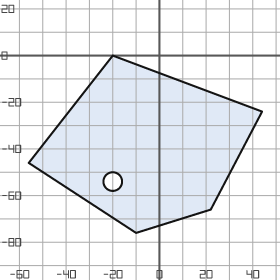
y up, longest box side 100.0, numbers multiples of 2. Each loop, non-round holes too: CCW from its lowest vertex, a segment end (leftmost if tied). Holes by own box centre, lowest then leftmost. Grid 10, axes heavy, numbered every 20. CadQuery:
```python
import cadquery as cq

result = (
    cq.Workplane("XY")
    .moveTo(-10.0, -76.0)
    .lineTo(22.0, -66.0)
    .lineTo(44.0, -24.0)
    .lineTo(-20.0, 0.0)
    .lineTo(-56.0, -46.0)
    .close()
    .moveTo(-20.0, -54.0)
    .circle(4.0)
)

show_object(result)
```